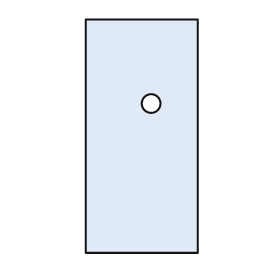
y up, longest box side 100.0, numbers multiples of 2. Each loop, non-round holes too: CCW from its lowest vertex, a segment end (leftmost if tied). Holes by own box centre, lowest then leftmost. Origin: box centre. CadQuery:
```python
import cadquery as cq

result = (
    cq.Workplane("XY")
    .moveTo(-24.0, -50.0)
    .lineTo(24.0, -50.0)
    .lineTo(24.0, 50.0)
    .lineTo(-24.0, 50.0)
    .close()
    .moveTo(4.0, 14.0)
    .circle(4.0)
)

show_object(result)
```